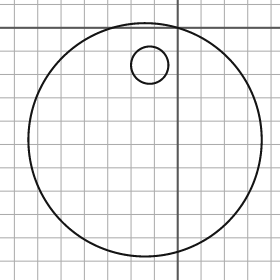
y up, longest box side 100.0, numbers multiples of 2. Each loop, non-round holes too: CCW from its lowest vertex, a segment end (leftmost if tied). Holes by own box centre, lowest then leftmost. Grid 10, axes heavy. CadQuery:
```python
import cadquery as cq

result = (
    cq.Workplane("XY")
    .moveTo(-14.0, -48.0)
    .circle(50.0)
    .moveTo(-12.0, -16.0)
    .circle(8.0)
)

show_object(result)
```